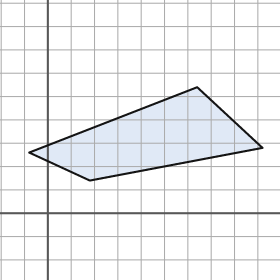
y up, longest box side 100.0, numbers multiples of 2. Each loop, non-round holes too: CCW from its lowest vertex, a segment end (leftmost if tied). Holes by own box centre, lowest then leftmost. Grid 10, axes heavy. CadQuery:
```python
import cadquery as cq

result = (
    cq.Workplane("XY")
    .moveTo(18.0, 14.0)
    .lineTo(92.0, 28.0)
    .lineTo(64.0, 54.0)
    .lineTo(-8.0, 26.0)
    .close()
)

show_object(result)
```